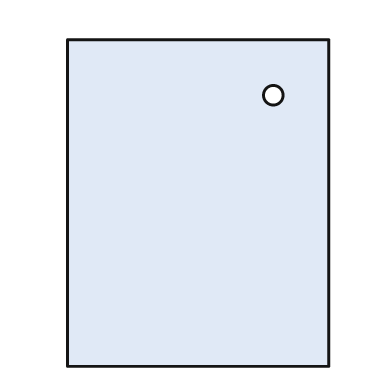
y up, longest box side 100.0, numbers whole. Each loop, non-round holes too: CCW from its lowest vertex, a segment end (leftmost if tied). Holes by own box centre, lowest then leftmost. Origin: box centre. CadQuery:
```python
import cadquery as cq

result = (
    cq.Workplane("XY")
    .moveTo(-40.0, -50.0)
    .lineTo(40.0, -50.0)
    .lineTo(40.0, 50.0)
    .lineTo(-40.0, 50.0)
    .close()
    .moveTo(23.0, 33.0)
    .circle(3.0)
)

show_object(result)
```